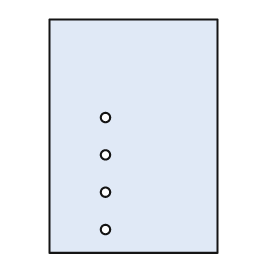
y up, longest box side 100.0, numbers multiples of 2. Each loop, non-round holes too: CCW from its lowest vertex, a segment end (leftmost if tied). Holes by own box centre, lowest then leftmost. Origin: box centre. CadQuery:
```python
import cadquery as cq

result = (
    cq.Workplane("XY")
    .moveTo(-36.0, -50.0)
    .lineTo(36.0, -50.0)
    .lineTo(36.0, 50.0)
    .lineTo(-36.0, 50.0)
    .close()
    .moveTo(-12.0, -40.0)
    .circle(2.0)
    .moveTo(-12.0, -24.0)
    .circle(2.0)
    .moveTo(-12.0, -8.0)
    .circle(2.0)
    .moveTo(-12.0, 8.0)
    .circle(2.0)
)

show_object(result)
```